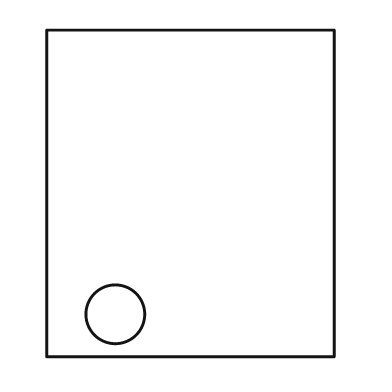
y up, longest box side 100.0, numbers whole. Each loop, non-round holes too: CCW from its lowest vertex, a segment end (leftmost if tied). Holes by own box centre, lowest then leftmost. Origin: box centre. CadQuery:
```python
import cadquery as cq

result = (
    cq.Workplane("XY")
    .moveTo(-44.0, -50.0)
    .lineTo(44.0, -50.0)
    .lineTo(44.0, 50.0)
    .lineTo(-44.0, 50.0)
    .close()
    .moveTo(-23.0, -37.0)
    .circle(9.0)
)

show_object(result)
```